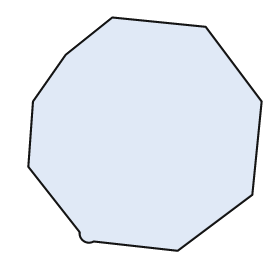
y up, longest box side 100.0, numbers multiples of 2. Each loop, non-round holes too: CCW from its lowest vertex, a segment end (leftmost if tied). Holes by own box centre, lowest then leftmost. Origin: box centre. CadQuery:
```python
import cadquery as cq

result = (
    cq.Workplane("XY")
    .moveTo(14.0, -50.0)
    .lineTo(46.0, -26.0)
    .lineTo(50.0, 14.0)
    .lineTo(26.0, 46.0)
    .lineTo(-14.0, 50.0)
    .lineTo(-34.0, 34.0)
    .lineTo(-48.0, 14.0)
    .lineTo(-50.0, -14.0)
    .lineTo(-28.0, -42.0)
    .threePointArc((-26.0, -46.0), (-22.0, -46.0))
    .close()
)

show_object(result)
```